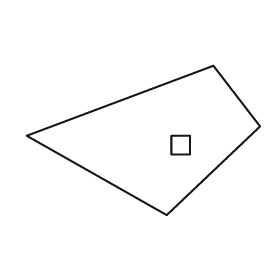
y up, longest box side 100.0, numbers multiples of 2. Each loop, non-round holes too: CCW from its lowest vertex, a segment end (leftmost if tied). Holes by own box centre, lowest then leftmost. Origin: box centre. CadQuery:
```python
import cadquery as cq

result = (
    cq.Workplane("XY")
    .moveTo(10.0, -32.0)
    .lineTo(50.0, 6.0)
    .lineTo(30.0, 32.0)
    .lineTo(-50.0, 2.0)
    .close()
    .moveTo(12.0, -6.0)
    .lineTo(20.0, -6.0)
    .lineTo(20.0, 2.0)
    .lineTo(12.0, 2.0)
    .close()
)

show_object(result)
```